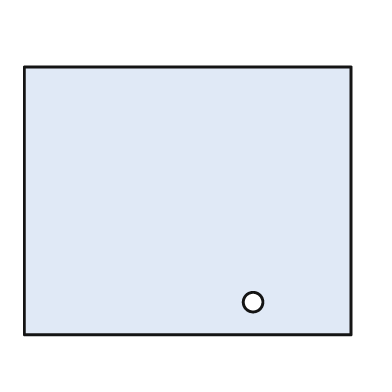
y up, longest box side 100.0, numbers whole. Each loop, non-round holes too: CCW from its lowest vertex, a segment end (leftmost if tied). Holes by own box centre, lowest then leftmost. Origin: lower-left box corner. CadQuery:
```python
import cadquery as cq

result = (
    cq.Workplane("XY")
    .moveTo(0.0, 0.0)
    .lineTo(100.0, 0.0)
    .lineTo(100.0, 82.0)
    .lineTo(0.0, 82.0)
    .close()
    .moveTo(70.0, 10.0)
    .circle(3.0)
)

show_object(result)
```